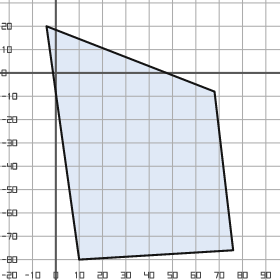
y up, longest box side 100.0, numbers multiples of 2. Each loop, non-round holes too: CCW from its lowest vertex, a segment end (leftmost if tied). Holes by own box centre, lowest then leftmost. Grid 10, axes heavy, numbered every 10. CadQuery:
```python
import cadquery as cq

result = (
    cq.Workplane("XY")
    .moveTo(10.0, -80.0)
    .lineTo(76.0, -76.0)
    .lineTo(68.0, -8.0)
    .lineTo(-4.0, 20.0)
    .close()
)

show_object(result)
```